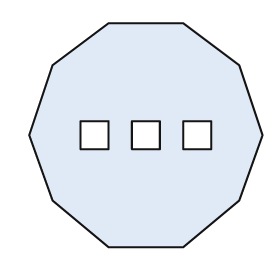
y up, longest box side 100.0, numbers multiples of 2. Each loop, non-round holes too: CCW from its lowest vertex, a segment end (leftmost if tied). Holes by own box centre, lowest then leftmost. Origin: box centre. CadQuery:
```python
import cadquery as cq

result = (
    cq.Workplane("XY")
    .moveTo(-16.0, -48.0)
    .lineTo(16.0, -48.0)
    .lineTo(40.0, -28.0)
    .lineTo(50.0, 0.0)
    .lineTo(40.0, 30.0)
    .lineTo(16.0, 48.0)
    .lineTo(-16.0, 48.0)
    .lineTo(-40.0, 30.0)
    .lineTo(-50.0, 0.0)
    .lineTo(-40.0, -28.0)
    .close()
    .moveTo(-28.0, -6.0)
    .lineTo(-16.0, -6.0)
    .lineTo(-16.0, 6.0)
    .lineTo(-28.0, 6.0)
    .close()
    .moveTo(-6.0, -6.0)
    .lineTo(6.0, -6.0)
    .lineTo(6.0, 6.0)
    .lineTo(-6.0, 6.0)
    .close()
    .moveTo(16.0, -6.0)
    .lineTo(28.0, -6.0)
    .lineTo(28.0, 6.0)
    .lineTo(16.0, 6.0)
    .close()
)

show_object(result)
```